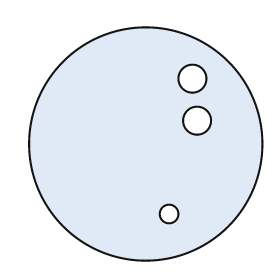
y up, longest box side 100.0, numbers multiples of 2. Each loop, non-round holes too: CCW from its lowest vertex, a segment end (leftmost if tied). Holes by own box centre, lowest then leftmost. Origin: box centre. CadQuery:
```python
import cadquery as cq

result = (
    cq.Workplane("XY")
    .moveTo(0.0, 0.0)
    .circle(50.0)
    .moveTo(10.0, -30.0)
    .circle(4.0)
    .moveTo(22.0, 10.0)
    .circle(6.0)
    .moveTo(20.0, 28.0)
    .circle(6.0)
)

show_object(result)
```